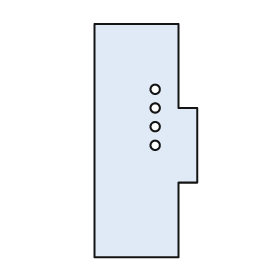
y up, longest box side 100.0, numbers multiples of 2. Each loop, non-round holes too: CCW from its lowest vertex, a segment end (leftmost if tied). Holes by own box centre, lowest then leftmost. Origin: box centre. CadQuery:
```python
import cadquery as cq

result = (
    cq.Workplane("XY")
    .moveTo(-22.0, -50.0)
    .lineTo(14.0, -50.0)
    .lineTo(14.0, -18.0)
    .lineTo(22.0, -18.0)
    .lineTo(22.0, 14.0)
    .lineTo(14.0, 14.0)
    .lineTo(14.0, 50.0)
    .lineTo(-22.0, 50.0)
    .close()
    .moveTo(4.0, -2.0)
    .circle(2.0)
    .moveTo(4.0, 6.0)
    .circle(2.0)
    .moveTo(4.0, 14.0)
    .circle(2.0)
    .moveTo(4.0, 22.0)
    .circle(2.0)
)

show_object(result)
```